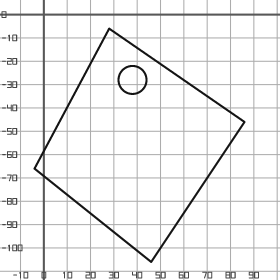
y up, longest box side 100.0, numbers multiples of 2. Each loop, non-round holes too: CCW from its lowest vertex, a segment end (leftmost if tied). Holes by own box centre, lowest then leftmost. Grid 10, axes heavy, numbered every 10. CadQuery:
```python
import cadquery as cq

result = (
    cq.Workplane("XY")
    .moveTo(46.0, -106.0)
    .lineTo(86.0, -46.0)
    .lineTo(28.0, -6.0)
    .lineTo(-4.0, -66.0)
    .close()
    .moveTo(38.0, -28.0)
    .circle(6.0)
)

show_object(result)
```